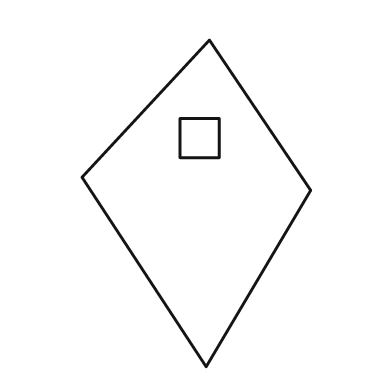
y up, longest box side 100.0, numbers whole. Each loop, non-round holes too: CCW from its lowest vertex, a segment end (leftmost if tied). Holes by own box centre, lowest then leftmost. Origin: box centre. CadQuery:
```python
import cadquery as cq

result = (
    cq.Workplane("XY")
    .moveTo(3.0, -50.0)
    .lineTo(35.0, 4.0)
    .lineTo(4.0, 50.0)
    .lineTo(-35.0, 8.0)
    .close()
    .moveTo(-5.0, 14.0)
    .lineTo(7.0, 14.0)
    .lineTo(7.0, 26.0)
    .lineTo(-5.0, 26.0)
    .close()
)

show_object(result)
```